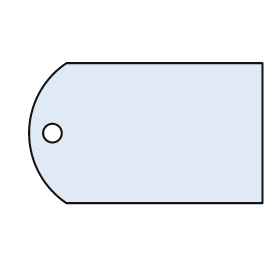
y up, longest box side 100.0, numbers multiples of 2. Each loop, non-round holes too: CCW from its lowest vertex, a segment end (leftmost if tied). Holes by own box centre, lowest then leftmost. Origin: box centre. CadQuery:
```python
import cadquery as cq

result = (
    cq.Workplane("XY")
    .moveTo(-34.0, -30.0)
    .lineTo(50.0, -30.0)
    .lineTo(50.0, 30.0)
    .lineTo(-34.0, 30.0)
    .threePointArc((-50.0, 0.0), (-34.0, -30.0))
    .close()
    .moveTo(-40.0, 0.0)
    .circle(4.0)
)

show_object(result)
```